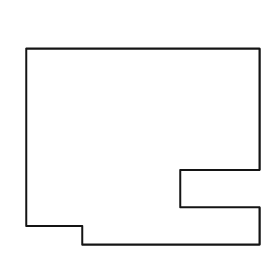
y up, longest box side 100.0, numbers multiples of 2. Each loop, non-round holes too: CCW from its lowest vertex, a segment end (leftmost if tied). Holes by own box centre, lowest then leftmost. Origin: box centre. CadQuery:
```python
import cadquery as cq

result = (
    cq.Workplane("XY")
    .moveTo(-26.0, -42.0)
    .lineTo(50.0, -42.0)
    .lineTo(50.0, -26.0)
    .lineTo(16.0, -26.0)
    .lineTo(16.0, -10.0)
    .lineTo(50.0, -10.0)
    .lineTo(50.0, 42.0)
    .lineTo(-50.0, 42.0)
    .lineTo(-50.0, -34.0)
    .lineTo(-26.0, -34.0)
    .close()
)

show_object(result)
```